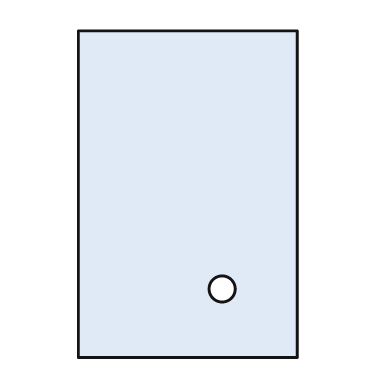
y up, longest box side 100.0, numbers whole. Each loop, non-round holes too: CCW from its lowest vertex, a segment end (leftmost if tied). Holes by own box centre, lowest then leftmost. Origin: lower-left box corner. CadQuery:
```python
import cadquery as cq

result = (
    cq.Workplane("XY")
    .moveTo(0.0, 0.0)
    .lineTo(67.0, 0.0)
    .lineTo(67.0, 100.0)
    .lineTo(0.0, 100.0)
    .close()
    .moveTo(44.0, 21.0)
    .circle(4.0)
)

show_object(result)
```